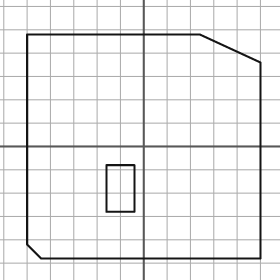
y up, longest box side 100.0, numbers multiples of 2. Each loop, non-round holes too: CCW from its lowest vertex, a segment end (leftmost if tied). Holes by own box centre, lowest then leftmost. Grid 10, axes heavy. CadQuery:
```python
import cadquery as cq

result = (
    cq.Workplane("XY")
    .moveTo(-44.0, -48.0)
    .lineTo(50.0, -48.0)
    .lineTo(50.0, 36.0)
    .lineTo(24.0, 48.0)
    .lineTo(-50.0, 48.0)
    .lineTo(-50.0, -42.0)
    .close()
    .moveTo(-16.0, -28.0)
    .lineTo(-4.0, -28.0)
    .lineTo(-4.0, -8.0)
    .lineTo(-16.0, -8.0)
    .close()
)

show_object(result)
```